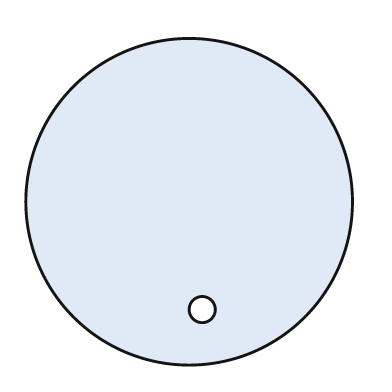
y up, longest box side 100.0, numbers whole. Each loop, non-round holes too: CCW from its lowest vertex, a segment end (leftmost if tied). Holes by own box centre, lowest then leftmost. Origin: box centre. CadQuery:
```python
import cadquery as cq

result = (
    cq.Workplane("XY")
    .moveTo(0.0, 0.0)
    .circle(50.0)
    .moveTo(4.0, -33.0)
    .circle(4.0)
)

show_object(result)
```